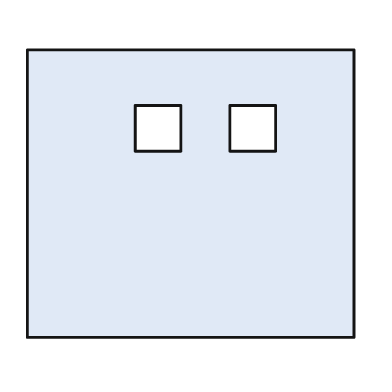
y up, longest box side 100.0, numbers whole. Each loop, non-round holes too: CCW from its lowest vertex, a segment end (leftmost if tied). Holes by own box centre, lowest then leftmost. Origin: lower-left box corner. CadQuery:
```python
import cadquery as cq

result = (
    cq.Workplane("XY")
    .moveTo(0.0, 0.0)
    .lineTo(100.0, 0.0)
    .lineTo(100.0, 88.0)
    .lineTo(0.0, 88.0)
    .close()
    .moveTo(33.0, 57.0)
    .lineTo(47.0, 57.0)
    .lineTo(47.0, 71.0)
    .lineTo(33.0, 71.0)
    .close()
    .moveTo(62.0, 57.0)
    .lineTo(76.0, 57.0)
    .lineTo(76.0, 71.0)
    .lineTo(62.0, 71.0)
    .close()
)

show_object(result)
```